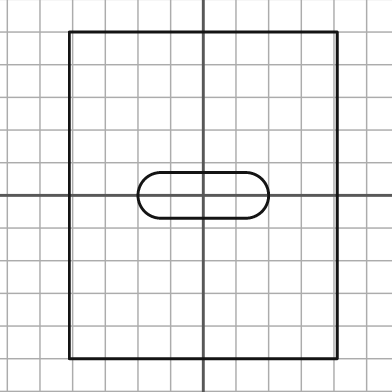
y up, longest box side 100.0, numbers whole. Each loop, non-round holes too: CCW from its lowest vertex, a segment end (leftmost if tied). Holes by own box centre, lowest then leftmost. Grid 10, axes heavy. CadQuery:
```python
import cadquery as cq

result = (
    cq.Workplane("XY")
    .moveTo(-41.0, -50.0)
    .lineTo(41.0, -50.0)
    .lineTo(41.0, 50.0)
    .lineTo(-41.0, 50.0)
    .close()
    .moveTo(-13.0, -7.0)
    .lineTo(13.0, -7.0)
    .threePointArc((20.0, 0.0), (13.0, 7.0))
    .lineTo(-13.0, 7.0)
    .threePointArc((-20.0, 0.0), (-13.0, -7.0))
    .close()
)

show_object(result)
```